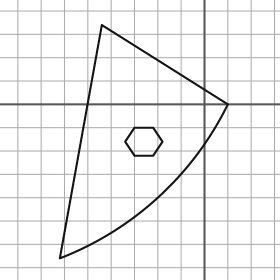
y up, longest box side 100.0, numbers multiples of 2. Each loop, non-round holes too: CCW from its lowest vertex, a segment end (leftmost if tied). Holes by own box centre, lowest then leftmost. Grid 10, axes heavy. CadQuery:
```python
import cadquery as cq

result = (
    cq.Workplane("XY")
    .moveTo(-62.0, -66.0)
    .threePointArc((-20.0, -40.0), (10.0, 0.0))
    .lineTo(-44.0, 34.0)
    .close()
    .moveTo(-30.0, -22.0)
    .lineTo(-22.0, -22.0)
    .lineTo(-18.0, -16.0)
    .lineTo(-22.0, -10.0)
    .lineTo(-30.0, -10.0)
    .lineTo(-34.0, -16.0)
    .close()
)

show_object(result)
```